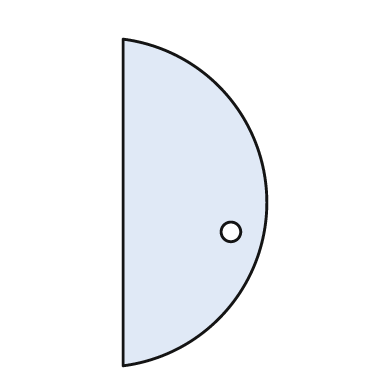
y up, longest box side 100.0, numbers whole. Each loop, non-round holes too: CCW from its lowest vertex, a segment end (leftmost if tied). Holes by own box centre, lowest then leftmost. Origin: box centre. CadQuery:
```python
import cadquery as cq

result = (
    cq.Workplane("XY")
    .moveTo(-22.0, -50.0)
    .threePointArc((22.0, 0.0), (-22.0, 50.0))
    .close()
    .moveTo(11.0, -9.0)
    .circle(3.0)
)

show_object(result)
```